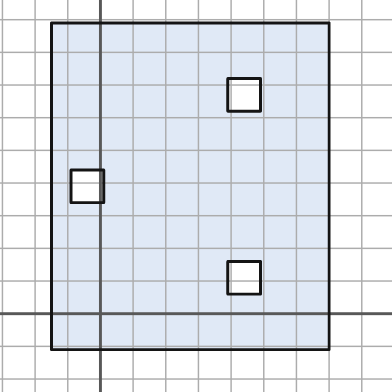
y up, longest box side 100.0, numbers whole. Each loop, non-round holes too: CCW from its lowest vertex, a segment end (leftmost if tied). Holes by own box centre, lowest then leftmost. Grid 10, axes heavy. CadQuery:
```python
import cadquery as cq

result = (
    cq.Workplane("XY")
    .moveTo(-15.0, -11.0)
    .lineTo(70.0, -11.0)
    .lineTo(70.0, 89.0)
    .lineTo(-15.0, 89.0)
    .close()
    .moveTo(39.0, 6.0)
    .lineTo(49.0, 6.0)
    .lineTo(49.0, 16.0)
    .lineTo(39.0, 16.0)
    .close()
    .moveTo(-9.0, 34.0)
    .lineTo(1.0, 34.0)
    .lineTo(1.0, 44.0)
    .lineTo(-9.0, 44.0)
    .close()
    .moveTo(39.0, 62.0)
    .lineTo(49.0, 62.0)
    .lineTo(49.0, 72.0)
    .lineTo(39.0, 72.0)
    .close()
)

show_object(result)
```